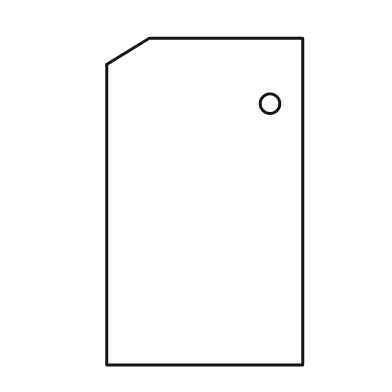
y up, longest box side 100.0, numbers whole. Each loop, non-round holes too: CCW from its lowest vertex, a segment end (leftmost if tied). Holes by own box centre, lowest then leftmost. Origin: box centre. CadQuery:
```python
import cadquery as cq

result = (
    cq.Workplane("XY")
    .moveTo(-30.0, -50.0)
    .lineTo(30.0, -50.0)
    .lineTo(30.0, 50.0)
    .lineTo(-17.0, 50.0)
    .lineTo(-30.0, 42.0)
    .close()
    .moveTo(20.0, 30.0)
    .circle(3.0)
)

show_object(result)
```